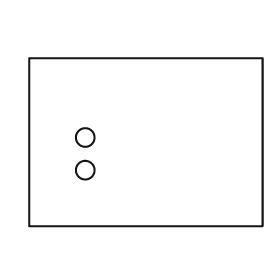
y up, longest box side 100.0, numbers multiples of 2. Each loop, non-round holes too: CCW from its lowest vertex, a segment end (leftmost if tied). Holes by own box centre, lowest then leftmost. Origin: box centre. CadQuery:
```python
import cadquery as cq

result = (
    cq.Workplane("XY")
    .moveTo(-50.0, -36.0)
    .lineTo(50.0, -36.0)
    .lineTo(50.0, 36.0)
    .lineTo(-50.0, 36.0)
    .close()
    .moveTo(-26.0, -12.0)
    .circle(4.0)
    .moveTo(-26.0, 2.0)
    .circle(4.0)
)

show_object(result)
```